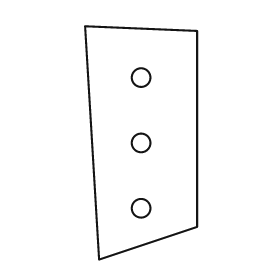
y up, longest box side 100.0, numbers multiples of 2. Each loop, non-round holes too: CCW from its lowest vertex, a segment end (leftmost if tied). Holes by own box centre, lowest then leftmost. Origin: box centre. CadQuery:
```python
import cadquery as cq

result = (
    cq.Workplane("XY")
    .moveTo(-18.0, -50.0)
    .lineTo(24.0, -36.0)
    .lineTo(24.0, 48.0)
    .lineTo(-24.0, 50.0)
    .close()
    .moveTo(0.0, -28.0)
    .circle(4.0)
    .moveTo(0.0, 0.0)
    .circle(4.0)
    .moveTo(0.0, 28.0)
    .circle(4.0)
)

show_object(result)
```